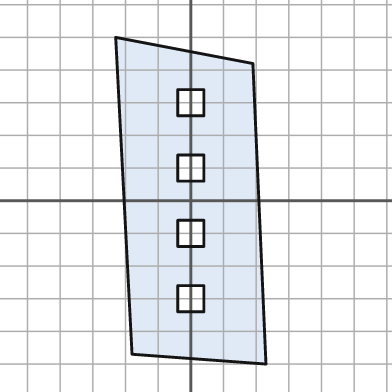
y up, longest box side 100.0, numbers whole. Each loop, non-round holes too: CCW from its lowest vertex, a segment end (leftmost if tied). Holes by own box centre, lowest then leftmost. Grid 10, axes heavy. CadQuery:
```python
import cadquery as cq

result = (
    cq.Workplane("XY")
    .moveTo(23.0, -50.0)
    .lineTo(19.0, 42.0)
    .lineTo(-23.0, 50.0)
    .lineTo(-18.0, -47.0)
    .close()
    .moveTo(-4.0, -34.0)
    .lineTo(4.0, -34.0)
    .lineTo(4.0, -26.0)
    .lineTo(-4.0, -26.0)
    .close()
    .moveTo(-4.0, -14.0)
    .lineTo(4.0, -14.0)
    .lineTo(4.0, -6.0)
    .lineTo(-4.0, -6.0)
    .close()
    .moveTo(-4.0, 6.0)
    .lineTo(4.0, 6.0)
    .lineTo(4.0, 14.0)
    .lineTo(-4.0, 14.0)
    .close()
    .moveTo(-4.0, 26.0)
    .lineTo(4.0, 26.0)
    .lineTo(4.0, 34.0)
    .lineTo(-4.0, 34.0)
    .close()
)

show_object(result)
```